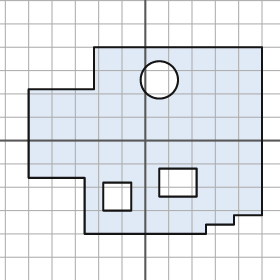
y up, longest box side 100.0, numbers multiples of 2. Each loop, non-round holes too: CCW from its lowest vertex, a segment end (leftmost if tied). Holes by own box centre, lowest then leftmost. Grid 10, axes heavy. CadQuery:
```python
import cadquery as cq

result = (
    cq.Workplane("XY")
    .moveTo(-26.0, -40.0)
    .lineTo(26.0, -40.0)
    .lineTo(26.0, -36.0)
    .lineTo(38.0, -36.0)
    .lineTo(38.0, -32.0)
    .lineTo(50.0, -32.0)
    .lineTo(50.0, 40.0)
    .lineTo(-22.0, 40.0)
    .lineTo(-22.0, 22.0)
    .lineTo(-50.0, 22.0)
    .lineTo(-50.0, -16.0)
    .lineTo(-26.0, -16.0)
    .close()
    .moveTo(-18.0, -30.0)
    .lineTo(-6.0, -30.0)
    .lineTo(-6.0, -18.0)
    .lineTo(-18.0, -18.0)
    .close()
    .moveTo(6.0, -24.0)
    .lineTo(22.0, -24.0)
    .lineTo(22.0, -12.0)
    .lineTo(6.0, -12.0)
    .close()
    .moveTo(6.0, 26.0)
    .circle(8.0)
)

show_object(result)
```